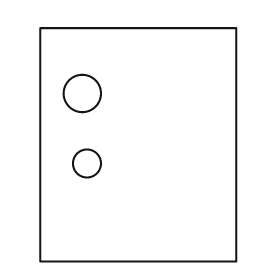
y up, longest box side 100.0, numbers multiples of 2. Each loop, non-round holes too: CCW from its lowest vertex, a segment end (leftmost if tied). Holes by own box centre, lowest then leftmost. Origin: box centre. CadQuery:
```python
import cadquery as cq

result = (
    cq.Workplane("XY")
    .moveTo(-42.0, -50.0)
    .lineTo(42.0, -50.0)
    .lineTo(42.0, 50.0)
    .lineTo(-42.0, 50.0)
    .close()
    .moveTo(-22.0, -8.0)
    .circle(6.0)
    .moveTo(-24.0, 22.0)
    .circle(8.0)
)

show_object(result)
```